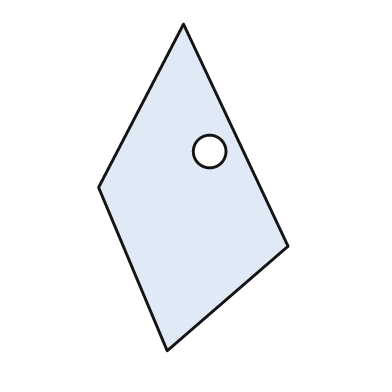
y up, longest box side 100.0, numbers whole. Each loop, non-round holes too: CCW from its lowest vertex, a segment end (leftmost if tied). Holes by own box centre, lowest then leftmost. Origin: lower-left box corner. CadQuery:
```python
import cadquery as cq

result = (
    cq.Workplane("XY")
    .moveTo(21.0, 0.0)
    .lineTo(58.0, 32.0)
    .lineTo(26.0, 100.0)
    .lineTo(0.0, 50.0)
    .close()
    .moveTo(34.0, 61.0)
    .circle(5.0)
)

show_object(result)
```